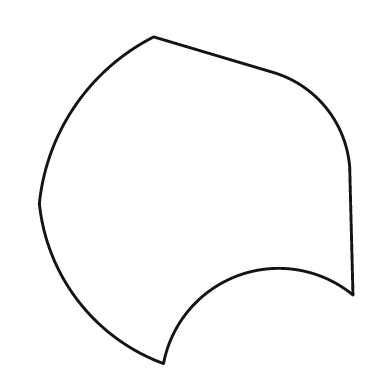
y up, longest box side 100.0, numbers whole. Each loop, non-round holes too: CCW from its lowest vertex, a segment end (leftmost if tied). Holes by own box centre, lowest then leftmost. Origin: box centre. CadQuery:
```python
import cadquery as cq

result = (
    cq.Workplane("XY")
    .moveTo(-10.0, -50.0)
    .threePointArc((13.0, -23.0), (48.0, -29.0))
    .lineTo(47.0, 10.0)
    .threePointArc((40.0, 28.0), (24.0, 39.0))
    .lineTo(-13.0, 50.0)
    .threePointArc((-37.0, 29.0), (-48.0, -1.0))
    .threePointArc((-36.0, -31.0), (-10.0, -50.0))
    .close()
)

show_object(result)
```